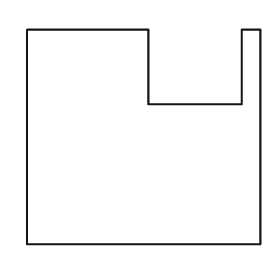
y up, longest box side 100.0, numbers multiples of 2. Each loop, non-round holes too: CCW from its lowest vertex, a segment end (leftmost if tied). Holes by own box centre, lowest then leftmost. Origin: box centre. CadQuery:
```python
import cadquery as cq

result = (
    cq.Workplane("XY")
    .moveTo(-50.0, -46.0)
    .lineTo(50.0, -46.0)
    .lineTo(50.0, 46.0)
    .lineTo(42.0, 46.0)
    .lineTo(42.0, 14.0)
    .lineTo(2.0, 14.0)
    .lineTo(2.0, 46.0)
    .lineTo(-50.0, 46.0)
    .close()
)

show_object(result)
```